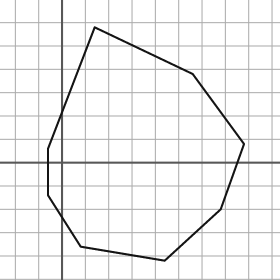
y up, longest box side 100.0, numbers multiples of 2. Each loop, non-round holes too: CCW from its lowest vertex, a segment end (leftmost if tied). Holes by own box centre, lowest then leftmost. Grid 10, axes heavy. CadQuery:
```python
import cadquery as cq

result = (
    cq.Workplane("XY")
    .moveTo(44.0, -42.0)
    .lineTo(68.0, -20.0)
    .lineTo(78.0, 8.0)
    .lineTo(56.0, 38.0)
    .lineTo(14.0, 58.0)
    .lineTo(-6.0, 6.0)
    .lineTo(-6.0, -14.0)
    .lineTo(8.0, -36.0)
    .close()
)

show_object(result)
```